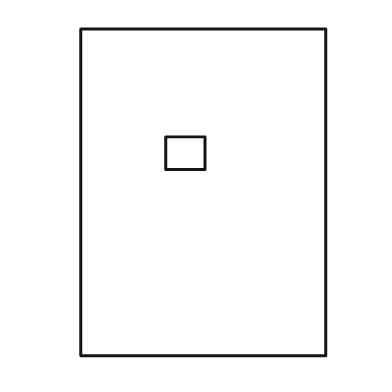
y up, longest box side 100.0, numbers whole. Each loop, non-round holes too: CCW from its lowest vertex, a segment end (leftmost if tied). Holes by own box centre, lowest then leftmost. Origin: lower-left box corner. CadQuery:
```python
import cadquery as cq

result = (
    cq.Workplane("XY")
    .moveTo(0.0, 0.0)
    .lineTo(75.0, 0.0)
    .lineTo(75.0, 100.0)
    .lineTo(0.0, 100.0)
    .close()
    .moveTo(26.0, 57.0)
    .lineTo(38.0, 57.0)
    .lineTo(38.0, 67.0)
    .lineTo(26.0, 67.0)
    .close()
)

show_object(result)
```